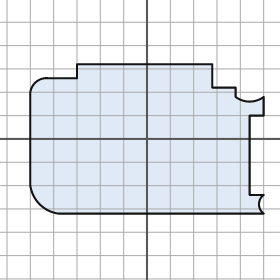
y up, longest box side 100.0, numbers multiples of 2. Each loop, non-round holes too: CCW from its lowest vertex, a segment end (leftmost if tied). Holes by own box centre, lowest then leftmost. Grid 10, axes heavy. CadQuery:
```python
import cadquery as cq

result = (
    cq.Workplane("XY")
    .moveTo(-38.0, -32.0)
    .lineTo(50.0, -32.0)
    .threePointArc((48.0, -28.0), (50.0, -24.0))
    .lineTo(44.0, -24.0)
    .lineTo(44.0, 10.0)
    .lineTo(50.0, 10.0)
    .lineTo(50.0, 18.0)
    .threePointArc((44.0, 16.0), (38.0, 18.0))
    .lineTo(38.0, 22.0)
    .lineTo(28.0, 22.0)
    .lineTo(28.0, 32.0)
    .lineTo(-30.0, 32.0)
    .lineTo(-30.0, 26.0)
    .lineTo(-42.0, 26.0)
    .threePointArc((-48.0, 24.0), (-50.0, 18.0))
    .lineTo(-50.0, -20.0)
    .threePointArc((-46.0, -28.0), (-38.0, -32.0))
    .close()
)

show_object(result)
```